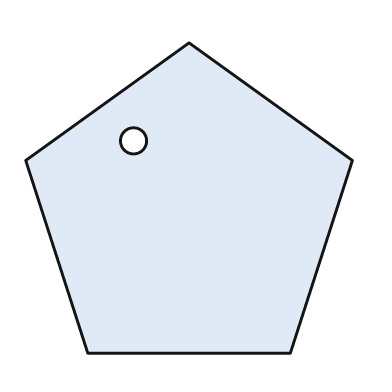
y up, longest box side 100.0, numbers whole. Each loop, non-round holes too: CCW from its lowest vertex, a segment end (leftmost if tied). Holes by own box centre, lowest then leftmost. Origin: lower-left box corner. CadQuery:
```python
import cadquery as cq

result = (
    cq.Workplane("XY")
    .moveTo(19.0, 0.0)
    .lineTo(81.0, 0.0)
    .lineTo(100.0, 59.0)
    .lineTo(50.0, 95.0)
    .lineTo(0.0, 59.0)
    .close()
    .moveTo(33.0, 65.0)
    .circle(4.0)
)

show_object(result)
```